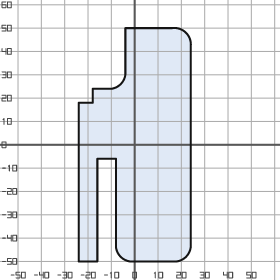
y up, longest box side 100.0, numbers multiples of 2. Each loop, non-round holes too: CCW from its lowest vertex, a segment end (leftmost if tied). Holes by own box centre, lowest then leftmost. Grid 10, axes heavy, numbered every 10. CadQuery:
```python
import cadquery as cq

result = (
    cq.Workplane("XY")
    .moveTo(-24.0, -50.0)
    .lineTo(-16.0, -50.0)
    .lineTo(-16.0, -6.0)
    .lineTo(-8.0, -6.0)
    .lineTo(-8.0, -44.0)
    .threePointArc((-6.0, -48.0), (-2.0, -50.0))
    .lineTo(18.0, -50.0)
    .threePointArc((22.0, -48.0), (24.0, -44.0))
    .lineTo(24.0, 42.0)
    .threePointArc((22.0, 48.0), (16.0, 50.0))
    .lineTo(-4.0, 50.0)
    .lineTo(-4.0, 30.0)
    .threePointArc((-6.0, 26.0), (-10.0, 24.0))
    .lineTo(-18.0, 24.0)
    .lineTo(-18.0, 18.0)
    .lineTo(-24.0, 18.0)
    .close()
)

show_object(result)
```